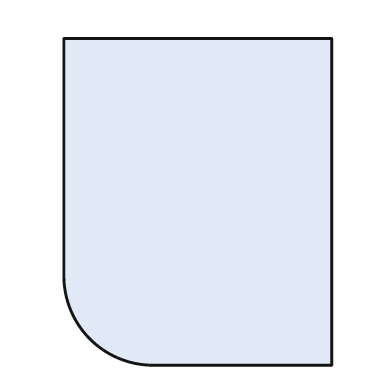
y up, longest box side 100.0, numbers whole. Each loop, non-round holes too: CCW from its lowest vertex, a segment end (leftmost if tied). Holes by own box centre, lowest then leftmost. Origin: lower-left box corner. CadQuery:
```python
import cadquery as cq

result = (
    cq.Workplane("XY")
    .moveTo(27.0, 0.0)
    .lineTo(82.0, 0.0)
    .lineTo(82.0, 100.0)
    .lineTo(0.0, 100.0)
    .lineTo(0.0, 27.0)
    .threePointArc((8.0, 8.0), (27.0, 0.0))
    .close()
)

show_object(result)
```